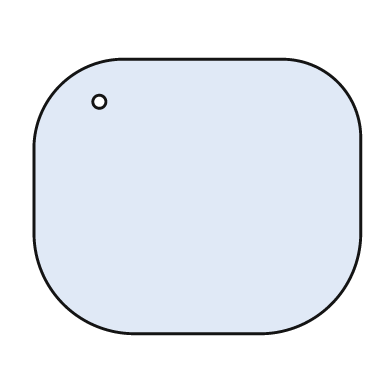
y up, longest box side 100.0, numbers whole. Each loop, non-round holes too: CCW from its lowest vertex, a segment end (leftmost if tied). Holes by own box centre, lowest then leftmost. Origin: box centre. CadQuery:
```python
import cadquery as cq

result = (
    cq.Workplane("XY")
    .moveTo(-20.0, -42.0)
    .lineTo(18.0, -42.0)
    .threePointArc((41.0, -33.0), (50.0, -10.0))
    .lineTo(50.0, 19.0)
    .threePointArc((43.0, 35.0), (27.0, 42.0))
    .lineTo(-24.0, 42.0)
    .threePointArc((-42.0, 34.0), (-50.0, 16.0))
    .lineTo(-50.0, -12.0)
    .threePointArc((-41.0, -33.0), (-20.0, -42.0))
    .close()
    .moveTo(-30.0, 29.0)
    .circle(2.0)
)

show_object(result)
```